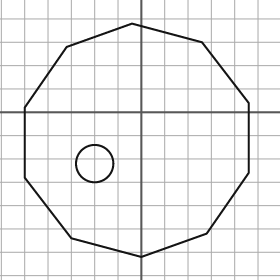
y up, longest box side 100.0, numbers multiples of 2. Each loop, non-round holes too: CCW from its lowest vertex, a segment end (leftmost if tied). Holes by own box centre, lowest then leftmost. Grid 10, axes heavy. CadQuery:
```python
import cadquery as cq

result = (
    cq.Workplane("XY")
    .moveTo(0.0, -62.0)
    .lineTo(28.0, -52.0)
    .lineTo(46.0, -26.0)
    .lineTo(46.0, 4.0)
    .lineTo(26.0, 30.0)
    .lineTo(-4.0, 38.0)
    .lineTo(-32.0, 28.0)
    .lineTo(-50.0, 2.0)
    .lineTo(-50.0, -28.0)
    .lineTo(-30.0, -54.0)
    .close()
    .moveTo(-20.0, -22.0)
    .circle(8.0)
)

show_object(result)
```